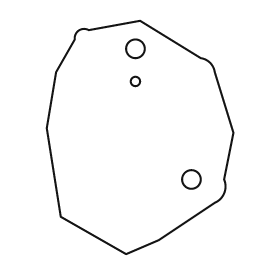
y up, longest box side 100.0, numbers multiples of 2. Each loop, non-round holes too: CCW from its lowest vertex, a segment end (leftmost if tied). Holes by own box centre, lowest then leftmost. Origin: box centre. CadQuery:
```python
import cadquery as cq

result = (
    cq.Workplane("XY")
    .moveTo(-6.0, -50.0)
    .lineTo(8.0, -44.0)
    .lineTo(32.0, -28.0)
    .threePointArc((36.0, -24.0), (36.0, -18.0))
    .lineTo(40.0, 2.0)
    .lineTo(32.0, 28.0)
    .threePointArc((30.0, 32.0), (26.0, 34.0))
    .lineTo(0.0, 50.0)
    .lineTo(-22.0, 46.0)
    .threePointArc((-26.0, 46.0), (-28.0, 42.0))
    .lineTo(-36.0, 28.0)
    .lineTo(-40.0, 4.0)
    .lineTo(-34.0, -34.0)
    .close()
    .moveTo(22.0, -18.0)
    .circle(4.0)
    .moveTo(-2.0, 24.0)
    .circle(2.0)
    .moveTo(-2.0, 38.0)
    .circle(4.0)
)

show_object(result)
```